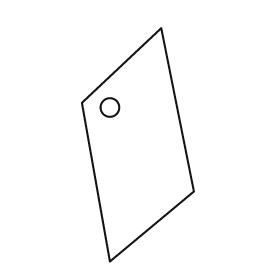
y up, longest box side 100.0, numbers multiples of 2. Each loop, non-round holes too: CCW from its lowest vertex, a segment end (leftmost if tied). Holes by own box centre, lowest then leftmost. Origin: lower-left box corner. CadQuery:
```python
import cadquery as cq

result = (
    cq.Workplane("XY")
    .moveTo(12.0, 0.0)
    .lineTo(48.0, 30.0)
    .lineTo(34.0, 100.0)
    .lineTo(0.0, 68.0)
    .close()
    .moveTo(12.0, 66.0)
    .circle(4.0)
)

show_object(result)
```